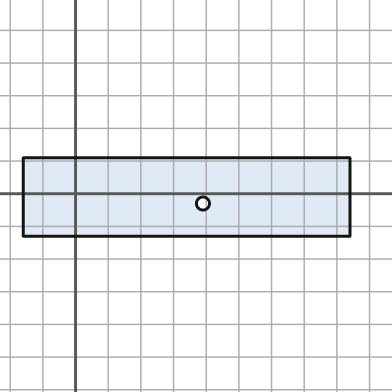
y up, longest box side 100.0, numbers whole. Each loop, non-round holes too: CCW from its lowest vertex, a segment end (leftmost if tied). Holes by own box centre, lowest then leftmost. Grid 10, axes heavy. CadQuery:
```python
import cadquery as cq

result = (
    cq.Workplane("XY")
    .moveTo(-16.0, -13.0)
    .lineTo(84.0, -13.0)
    .lineTo(84.0, 11.0)
    .lineTo(-16.0, 11.0)
    .close()
    .moveTo(39.0, -3.0)
    .circle(2.0)
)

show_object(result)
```